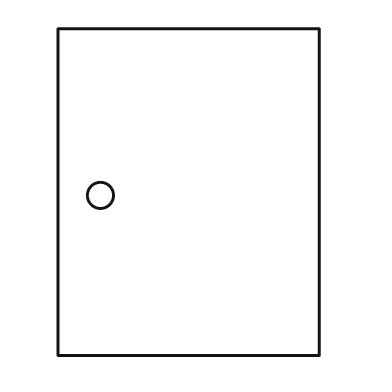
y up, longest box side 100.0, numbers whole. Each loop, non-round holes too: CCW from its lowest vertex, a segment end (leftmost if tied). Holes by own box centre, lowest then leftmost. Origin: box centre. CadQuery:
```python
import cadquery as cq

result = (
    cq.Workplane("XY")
    .moveTo(-40.0, -50.0)
    .lineTo(40.0, -50.0)
    .lineTo(40.0, 50.0)
    .lineTo(-40.0, 50.0)
    .close()
    .moveTo(-27.0, -1.0)
    .circle(4.0)
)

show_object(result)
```